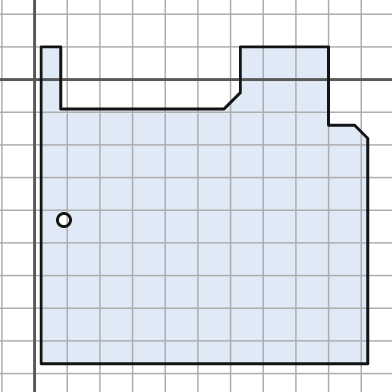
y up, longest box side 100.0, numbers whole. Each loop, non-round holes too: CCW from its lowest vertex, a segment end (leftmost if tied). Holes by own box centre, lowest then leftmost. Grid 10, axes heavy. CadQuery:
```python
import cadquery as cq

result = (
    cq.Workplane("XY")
    .moveTo(2.0, -87.0)
    .lineTo(102.0, -87.0)
    .lineTo(102.0, -18.0)
    .lineTo(98.0, -14.0)
    .lineTo(90.0, -14.0)
    .lineTo(90.0, 10.0)
    .lineTo(63.0, 10.0)
    .lineTo(63.0, -4.0)
    .lineTo(58.0, -9.0)
    .lineTo(8.0, -9.0)
    .lineTo(8.0, 10.0)
    .lineTo(2.0, 10.0)
    .close()
    .moveTo(9.0, -43.0)
    .circle(2.0)
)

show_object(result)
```